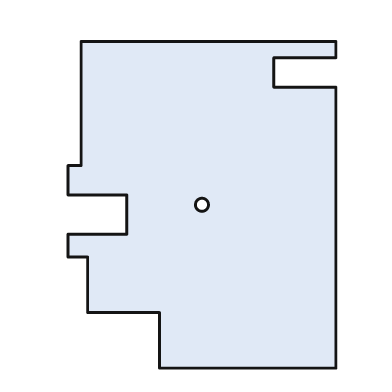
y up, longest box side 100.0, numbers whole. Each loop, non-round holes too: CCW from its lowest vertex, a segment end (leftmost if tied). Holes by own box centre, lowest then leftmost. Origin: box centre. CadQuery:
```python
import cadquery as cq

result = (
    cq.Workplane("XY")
    .moveTo(-13.0, -50.0)
    .lineTo(41.0, -50.0)
    .lineTo(41.0, 36.0)
    .lineTo(22.0, 36.0)
    .lineTo(22.0, 45.0)
    .lineTo(41.0, 45.0)
    .lineTo(41.0, 50.0)
    .lineTo(-37.0, 50.0)
    .lineTo(-37.0, 12.0)
    .lineTo(-41.0, 12.0)
    .lineTo(-41.0, 3.0)
    .lineTo(-23.0, 3.0)
    .lineTo(-23.0, -9.0)
    .lineTo(-41.0, -9.0)
    .lineTo(-41.0, -16.0)
    .lineTo(-35.0, -16.0)
    .lineTo(-35.0, -33.0)
    .lineTo(-13.0, -33.0)
    .close()
    .moveTo(0.0, 0.0)
    .circle(2.0)
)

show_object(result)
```